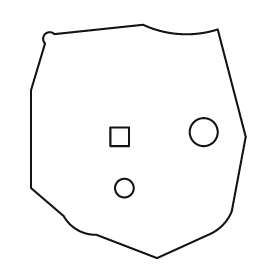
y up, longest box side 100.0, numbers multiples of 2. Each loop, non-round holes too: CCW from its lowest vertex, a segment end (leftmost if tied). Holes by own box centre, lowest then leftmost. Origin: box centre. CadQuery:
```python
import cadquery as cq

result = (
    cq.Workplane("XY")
    .moveTo(8.0, -50.0)
    .lineTo(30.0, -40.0)
    .threePointArc((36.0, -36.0), (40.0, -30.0))
    .lineTo(46.0, 2.0)
    .lineTo(34.0, 48.0)
    .threePointArc((18.0, 46.0), (2.0, 50.0))
    .lineTo(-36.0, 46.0)
    .threePointArc((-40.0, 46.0), (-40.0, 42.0))
    .lineTo(-46.0, 22.0)
    .lineTo(-46.0, -20.0)
    .lineTo(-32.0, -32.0)
    .threePointArc((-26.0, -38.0), (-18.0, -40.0))
    .close()
    .moveTo(-6.0, -20.0)
    .circle(4.0)
    .moveTo(-12.0, -2.0)
    .lineTo(-4.0, -2.0)
    .lineTo(-4.0, 6.0)
    .lineTo(-12.0, 6.0)
    .close()
    .moveTo(28.0, 4.0)
    .circle(6.0)
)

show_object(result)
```